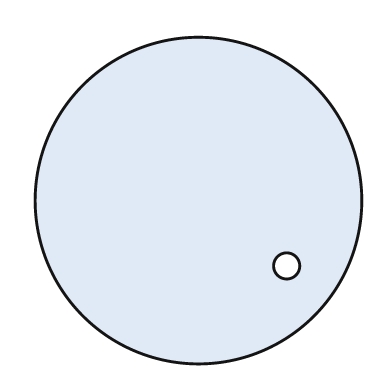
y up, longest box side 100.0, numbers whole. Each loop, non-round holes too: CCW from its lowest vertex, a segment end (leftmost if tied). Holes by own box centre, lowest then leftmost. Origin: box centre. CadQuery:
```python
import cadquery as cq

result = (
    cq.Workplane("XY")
    .moveTo(0.0, 0.0)
    .circle(50.0)
    .moveTo(27.0, -20.0)
    .circle(4.0)
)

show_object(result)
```